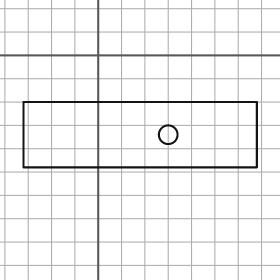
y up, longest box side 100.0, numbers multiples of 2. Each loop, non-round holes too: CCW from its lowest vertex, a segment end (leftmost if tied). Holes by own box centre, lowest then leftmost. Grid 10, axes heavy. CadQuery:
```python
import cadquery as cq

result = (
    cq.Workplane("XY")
    .moveTo(-32.0, -48.0)
    .lineTo(68.0, -48.0)
    .lineTo(68.0, -20.0)
    .lineTo(-32.0, -20.0)
    .close()
    .moveTo(30.0, -34.0)
    .circle(4.0)
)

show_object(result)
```